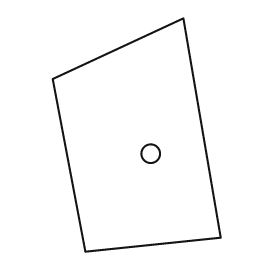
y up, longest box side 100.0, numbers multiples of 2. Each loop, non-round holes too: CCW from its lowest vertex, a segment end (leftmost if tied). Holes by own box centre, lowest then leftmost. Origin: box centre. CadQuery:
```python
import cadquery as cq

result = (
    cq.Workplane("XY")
    .moveTo(-22.0, -50.0)
    .lineTo(36.0, -44.0)
    .lineTo(20.0, 50.0)
    .lineTo(-36.0, 24.0)
    .close()
    .moveTo(6.0, -8.0)
    .circle(4.0)
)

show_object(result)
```